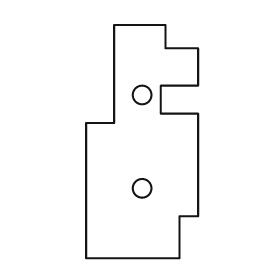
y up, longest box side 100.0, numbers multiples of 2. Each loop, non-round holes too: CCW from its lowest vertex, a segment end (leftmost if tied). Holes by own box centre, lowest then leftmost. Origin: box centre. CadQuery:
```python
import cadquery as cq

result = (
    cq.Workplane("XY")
    .moveTo(-24.0, -50.0)
    .lineTo(16.0, -50.0)
    .lineTo(16.0, -32.0)
    .lineTo(24.0, -32.0)
    .lineTo(24.0, 12.0)
    .lineTo(8.0, 12.0)
    .lineTo(8.0, 24.0)
    .lineTo(24.0, 24.0)
    .lineTo(24.0, 40.0)
    .lineTo(10.0, 40.0)
    .lineTo(10.0, 50.0)
    .lineTo(-12.0, 50.0)
    .lineTo(-12.0, 8.0)
    .lineTo(-24.0, 8.0)
    .close()
    .moveTo(0.0, -20.0)
    .circle(4.0)
    .moveTo(0.0, 20.0)
    .circle(4.0)
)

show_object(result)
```